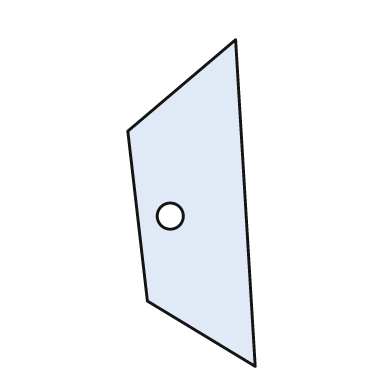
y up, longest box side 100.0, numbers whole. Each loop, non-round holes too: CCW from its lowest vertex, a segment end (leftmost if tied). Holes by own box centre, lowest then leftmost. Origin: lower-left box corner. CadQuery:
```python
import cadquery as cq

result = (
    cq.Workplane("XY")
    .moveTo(39.0, 0.0)
    .lineTo(33.0, 100.0)
    .lineTo(0.0, 72.0)
    .lineTo(6.0, 20.0)
    .close()
    .moveTo(13.0, 46.0)
    .circle(4.0)
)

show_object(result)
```